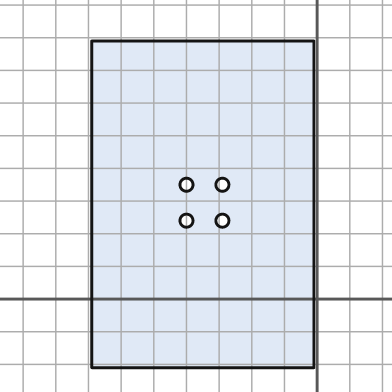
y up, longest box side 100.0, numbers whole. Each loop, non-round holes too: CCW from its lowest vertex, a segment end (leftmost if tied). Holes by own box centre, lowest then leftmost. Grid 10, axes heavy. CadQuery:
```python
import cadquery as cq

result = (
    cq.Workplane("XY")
    .moveTo(-69.0, -21.0)
    .lineTo(-1.0, -21.0)
    .lineTo(-1.0, 79.0)
    .lineTo(-69.0, 79.0)
    .close()
    .moveTo(-40.0, 24.0)
    .circle(2.0)
    .moveTo(-29.0, 24.0)
    .circle(2.0)
    .moveTo(-40.0, 35.0)
    .circle(2.0)
    .moveTo(-29.0, 35.0)
    .circle(2.0)
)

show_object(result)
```